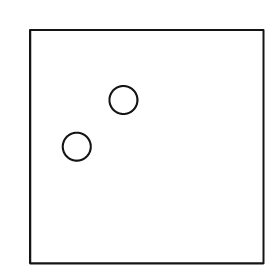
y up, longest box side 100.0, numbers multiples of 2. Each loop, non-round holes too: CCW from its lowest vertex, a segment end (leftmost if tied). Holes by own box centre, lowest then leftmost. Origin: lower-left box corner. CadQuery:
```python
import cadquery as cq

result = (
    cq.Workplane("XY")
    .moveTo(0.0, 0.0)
    .lineTo(100.0, 0.0)
    .lineTo(100.0, 100.0)
    .lineTo(0.0, 100.0)
    .close()
    .moveTo(20.0, 50.0)
    .circle(6.0)
    .moveTo(40.0, 70.0)
    .circle(6.0)
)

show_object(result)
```